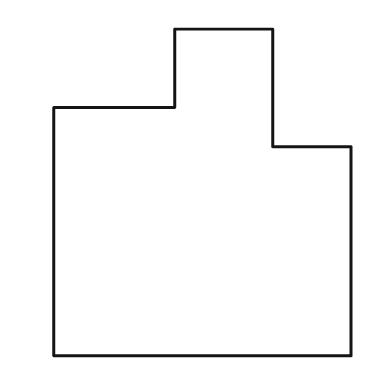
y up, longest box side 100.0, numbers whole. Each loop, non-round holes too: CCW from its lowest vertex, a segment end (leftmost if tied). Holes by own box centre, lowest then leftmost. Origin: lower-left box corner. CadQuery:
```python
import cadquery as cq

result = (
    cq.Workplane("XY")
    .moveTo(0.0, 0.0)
    .lineTo(91.0, 0.0)
    .lineTo(91.0, 64.0)
    .lineTo(67.0, 64.0)
    .lineTo(67.0, 100.0)
    .lineTo(37.0, 100.0)
    .lineTo(37.0, 76.0)
    .lineTo(0.0, 76.0)
    .close()
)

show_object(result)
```